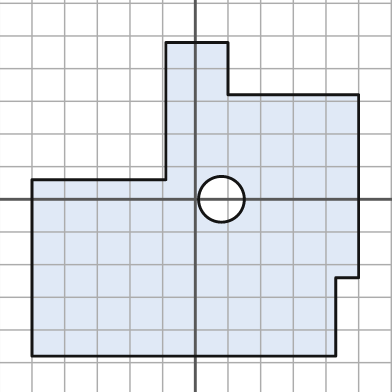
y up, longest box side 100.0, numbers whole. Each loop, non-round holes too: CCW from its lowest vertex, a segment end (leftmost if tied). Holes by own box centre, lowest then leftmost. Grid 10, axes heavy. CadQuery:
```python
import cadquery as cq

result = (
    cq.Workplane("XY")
    .moveTo(-50.0, -48.0)
    .lineTo(43.0, -48.0)
    .lineTo(43.0, -24.0)
    .lineTo(50.0, -24.0)
    .lineTo(50.0, 32.0)
    .lineTo(10.0, 32.0)
    .lineTo(10.0, 48.0)
    .lineTo(-9.0, 48.0)
    .lineTo(-9.0, 6.0)
    .lineTo(-50.0, 6.0)
    .close()
    .moveTo(8.0, 0.0)
    .circle(7.0)
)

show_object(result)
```